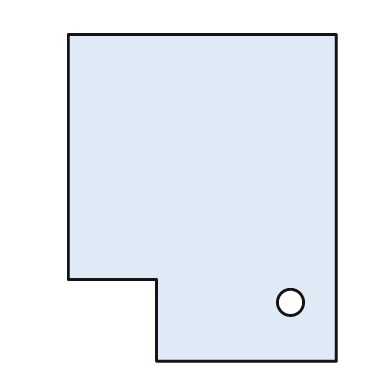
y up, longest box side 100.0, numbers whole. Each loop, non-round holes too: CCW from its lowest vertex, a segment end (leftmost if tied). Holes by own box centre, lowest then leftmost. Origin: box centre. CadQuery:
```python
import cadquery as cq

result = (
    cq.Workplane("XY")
    .moveTo(-14.0, -50.0)
    .lineTo(41.0, -50.0)
    .lineTo(41.0, 50.0)
    .lineTo(-41.0, 50.0)
    .lineTo(-41.0, -25.0)
    .lineTo(-14.0, -25.0)
    .close()
    .moveTo(27.0, -32.0)
    .circle(4.0)
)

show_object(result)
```